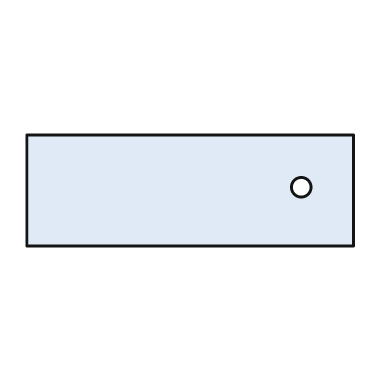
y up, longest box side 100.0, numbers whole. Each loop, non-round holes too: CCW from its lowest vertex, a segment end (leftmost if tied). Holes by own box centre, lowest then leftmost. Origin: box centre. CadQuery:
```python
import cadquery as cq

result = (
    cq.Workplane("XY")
    .moveTo(-50.0, -17.0)
    .lineTo(50.0, -17.0)
    .lineTo(50.0, 17.0)
    .lineTo(-50.0, 17.0)
    .close()
    .moveTo(34.0, 1.0)
    .circle(3.0)
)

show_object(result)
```